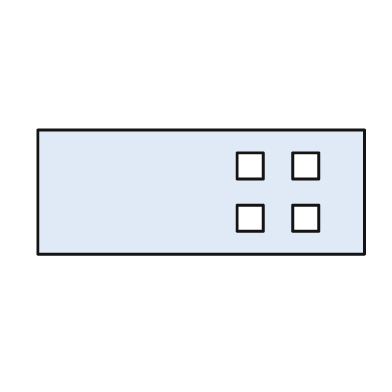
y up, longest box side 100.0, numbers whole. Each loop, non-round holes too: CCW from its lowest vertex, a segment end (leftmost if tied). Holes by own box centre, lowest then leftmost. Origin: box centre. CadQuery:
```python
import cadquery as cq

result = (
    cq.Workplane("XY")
    .moveTo(-50.0, -19.0)
    .lineTo(50.0, -19.0)
    .lineTo(50.0, 19.0)
    .lineTo(-50.0, 19.0)
    .close()
    .moveTo(11.0, -12.0)
    .lineTo(19.0, -12.0)
    .lineTo(19.0, -4.0)
    .lineTo(11.0, -4.0)
    .close()
    .moveTo(28.0, -12.0)
    .lineTo(36.0, -12.0)
    .lineTo(36.0, -4.0)
    .lineTo(28.0, -4.0)
    .close()
    .moveTo(11.0, 4.0)
    .lineTo(19.0, 4.0)
    .lineTo(19.0, 12.0)
    .lineTo(11.0, 12.0)
    .close()
    .moveTo(28.0, 4.0)
    .lineTo(36.0, 4.0)
    .lineTo(36.0, 12.0)
    .lineTo(28.0, 12.0)
    .close()
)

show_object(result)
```